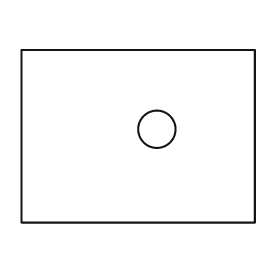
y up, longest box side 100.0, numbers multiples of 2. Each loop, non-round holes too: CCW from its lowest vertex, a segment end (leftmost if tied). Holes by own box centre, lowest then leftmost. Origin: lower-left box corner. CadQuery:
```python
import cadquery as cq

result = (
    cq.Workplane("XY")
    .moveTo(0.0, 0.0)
    .lineTo(100.0, 0.0)
    .lineTo(100.0, 74.0)
    .lineTo(0.0, 74.0)
    .close()
    .moveTo(58.0, 40.0)
    .circle(8.0)
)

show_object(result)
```